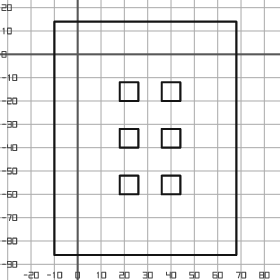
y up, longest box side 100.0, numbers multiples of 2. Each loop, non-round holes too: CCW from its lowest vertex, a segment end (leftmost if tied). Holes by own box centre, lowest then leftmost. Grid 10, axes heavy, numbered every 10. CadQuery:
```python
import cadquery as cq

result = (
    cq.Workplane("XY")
    .moveTo(-10.0, -86.0)
    .lineTo(68.0, -86.0)
    .lineTo(68.0, 14.0)
    .lineTo(-10.0, 14.0)
    .close()
    .moveTo(18.0, -60.0)
    .lineTo(26.0, -60.0)
    .lineTo(26.0, -52.0)
    .lineTo(18.0, -52.0)
    .close()
    .moveTo(36.0, -60.0)
    .lineTo(44.0, -60.0)
    .lineTo(44.0, -52.0)
    .lineTo(36.0, -52.0)
    .close()
    .moveTo(18.0, -40.0)
    .lineTo(26.0, -40.0)
    .lineTo(26.0, -32.0)
    .lineTo(18.0, -32.0)
    .close()
    .moveTo(36.0, -40.0)
    .lineTo(44.0, -40.0)
    .lineTo(44.0, -32.0)
    .lineTo(36.0, -32.0)
    .close()
    .moveTo(18.0, -20.0)
    .lineTo(26.0, -20.0)
    .lineTo(26.0, -12.0)
    .lineTo(18.0, -12.0)
    .close()
    .moveTo(36.0, -20.0)
    .lineTo(44.0, -20.0)
    .lineTo(44.0, -12.0)
    .lineTo(36.0, -12.0)
    .close()
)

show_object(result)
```